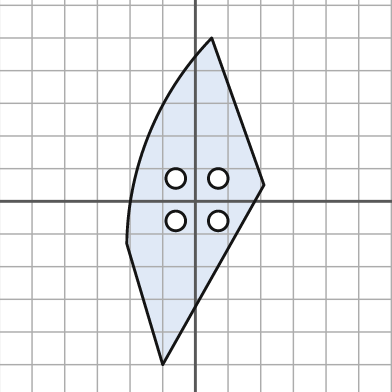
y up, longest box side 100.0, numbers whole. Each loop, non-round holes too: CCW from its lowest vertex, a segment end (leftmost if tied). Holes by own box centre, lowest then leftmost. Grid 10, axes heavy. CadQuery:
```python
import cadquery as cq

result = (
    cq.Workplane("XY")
    .moveTo(-10.0, -50.0)
    .lineTo(21.0, 5.0)
    .lineTo(5.0, 50.0)
    .threePointArc((-14.0, 21.0), (-21.0, -13.0))
    .close()
    .moveTo(-6.0, -6.0)
    .circle(3.0)
    .moveTo(7.0, -6.0)
    .circle(3.0)
    .moveTo(-6.0, 7.0)
    .circle(3.0)
    .moveTo(7.0, 7.0)
    .circle(3.0)
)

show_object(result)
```